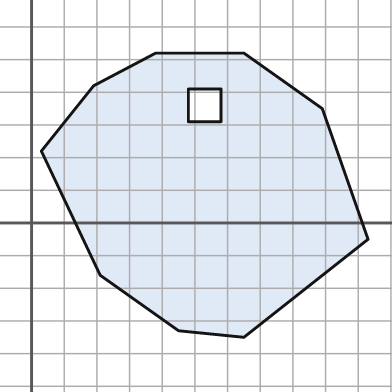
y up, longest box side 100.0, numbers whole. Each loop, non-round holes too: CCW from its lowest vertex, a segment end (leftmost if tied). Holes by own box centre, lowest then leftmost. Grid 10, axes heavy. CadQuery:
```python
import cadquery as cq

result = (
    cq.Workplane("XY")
    .moveTo(65.0, -35.0)
    .lineTo(103.0, -5.0)
    .lineTo(89.0, 35.0)
    .lineTo(65.0, 52.0)
    .lineTo(38.0, 52.0)
    .lineTo(19.0, 42.0)
    .lineTo(3.0, 22.0)
    .lineTo(21.0, -16.0)
    .lineTo(45.0, -33.0)
    .close()
    .moveTo(48.0, 31.0)
    .lineTo(58.0, 31.0)
    .lineTo(58.0, 41.0)
    .lineTo(48.0, 41.0)
    .close()
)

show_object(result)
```